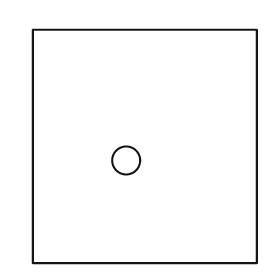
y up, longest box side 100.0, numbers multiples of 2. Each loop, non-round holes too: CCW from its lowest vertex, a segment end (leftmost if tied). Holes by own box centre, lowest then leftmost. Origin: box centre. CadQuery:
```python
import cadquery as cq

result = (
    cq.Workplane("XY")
    .moveTo(-48.0, -50.0)
    .lineTo(48.0, -50.0)
    .lineTo(48.0, 50.0)
    .lineTo(-48.0, 50.0)
    .close()
    .moveTo(-8.0, -6.0)
    .circle(6.0)
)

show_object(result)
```